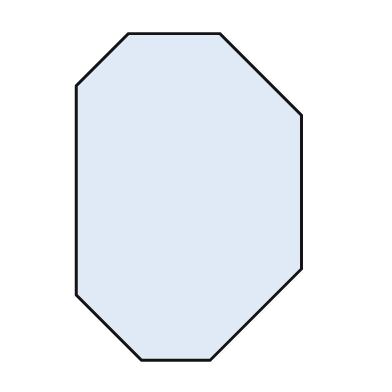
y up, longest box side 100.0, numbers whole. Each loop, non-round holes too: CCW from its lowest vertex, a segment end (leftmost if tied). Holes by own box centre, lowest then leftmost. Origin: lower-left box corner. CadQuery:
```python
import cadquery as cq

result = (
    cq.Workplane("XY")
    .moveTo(20.0, 0.0)
    .lineTo(41.0, 0.0)
    .lineTo(69.0, 28.0)
    .lineTo(69.0, 75.0)
    .lineTo(44.0, 100.0)
    .lineTo(16.0, 100.0)
    .lineTo(0.0, 84.0)
    .lineTo(0.0, 20.0)
    .close()
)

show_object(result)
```